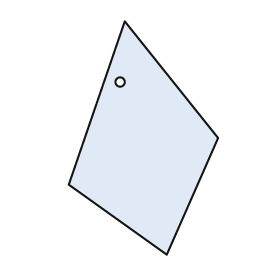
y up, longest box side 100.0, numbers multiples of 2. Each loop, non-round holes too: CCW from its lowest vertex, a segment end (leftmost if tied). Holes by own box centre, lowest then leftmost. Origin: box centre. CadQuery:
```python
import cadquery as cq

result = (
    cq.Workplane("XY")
    .moveTo(10.0, -50.0)
    .lineTo(32.0, 0.0)
    .lineTo(-8.0, 50.0)
    .lineTo(-32.0, -20.0)
    .close()
    .moveTo(-10.0, 24.0)
    .circle(2.0)
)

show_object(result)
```